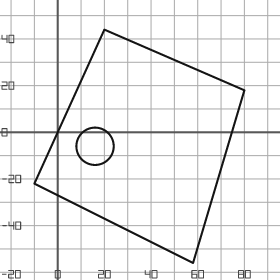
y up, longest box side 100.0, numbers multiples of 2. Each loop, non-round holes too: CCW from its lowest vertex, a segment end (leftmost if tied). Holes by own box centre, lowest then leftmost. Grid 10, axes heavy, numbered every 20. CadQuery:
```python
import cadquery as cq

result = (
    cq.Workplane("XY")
    .moveTo(58.0, -56.0)
    .lineTo(80.0, 18.0)
    .lineTo(20.0, 44.0)
    .lineTo(-10.0, -22.0)
    .close()
    .moveTo(16.0, -6.0)
    .circle(8.0)
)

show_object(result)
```